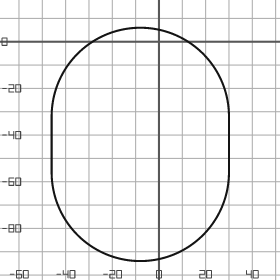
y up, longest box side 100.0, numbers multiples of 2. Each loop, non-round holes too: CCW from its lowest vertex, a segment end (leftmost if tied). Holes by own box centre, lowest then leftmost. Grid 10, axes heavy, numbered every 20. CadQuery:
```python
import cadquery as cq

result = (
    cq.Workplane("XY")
    .moveTo(-46.0, -56.0)
    .threePointArc((-8.0, -94.0), (30.0, -56.0))
    .lineTo(30.0, -32.0)
    .threePointArc((-8.0, 6.0), (-46.0, -32.0))
    .close()
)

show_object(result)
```